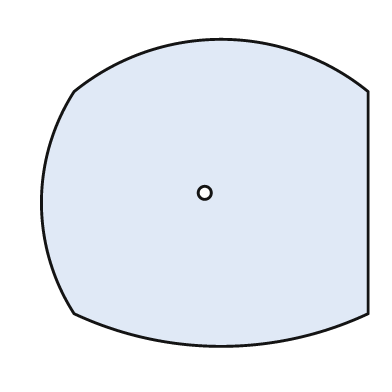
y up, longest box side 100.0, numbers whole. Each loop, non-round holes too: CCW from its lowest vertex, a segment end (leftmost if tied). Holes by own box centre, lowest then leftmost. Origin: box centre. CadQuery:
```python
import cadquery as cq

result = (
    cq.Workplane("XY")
    .moveTo(-40.0, -37.0)
    .threePointArc((5.0, -47.0), (50.0, -37.0))
    .lineTo(50.0, 31.0)
    .threePointArc((5.0, 47.0), (-40.0, 31.0))
    .threePointArc((-50.0, -3.0), (-40.0, -37.0))
    .close()
    .moveTo(0.0, 0.0)
    .circle(2.0)
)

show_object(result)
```